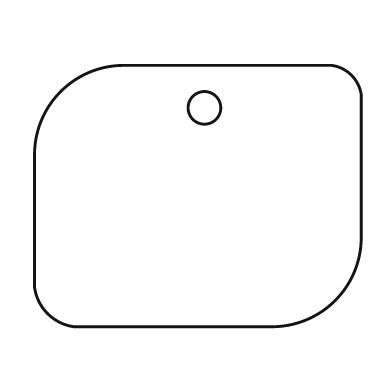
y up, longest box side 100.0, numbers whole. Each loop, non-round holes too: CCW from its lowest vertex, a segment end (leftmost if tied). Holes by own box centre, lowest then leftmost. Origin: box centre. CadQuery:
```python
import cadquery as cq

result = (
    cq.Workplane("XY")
    .moveTo(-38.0, -40.0)
    .lineTo(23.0, -40.0)
    .threePointArc((42.0, -32.0), (50.0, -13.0))
    .lineTo(50.0, 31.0)
    .threePointArc((47.0, 37.0), (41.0, 40.0))
    .lineTo(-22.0, 40.0)
    .threePointArc((-42.0, 32.0), (-50.0, 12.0))
    .lineTo(-50.0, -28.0)
    .threePointArc((-46.0, -36.0), (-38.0, -40.0))
    .close()
    .moveTo(2.0, 27.0)
    .circle(5.0)
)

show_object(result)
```